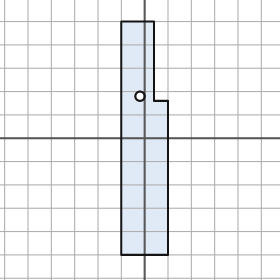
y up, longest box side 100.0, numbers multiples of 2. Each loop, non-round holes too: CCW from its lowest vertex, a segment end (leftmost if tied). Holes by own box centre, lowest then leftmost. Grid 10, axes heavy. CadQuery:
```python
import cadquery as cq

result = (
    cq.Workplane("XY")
    .moveTo(-10.0, -50.0)
    .lineTo(10.0, -50.0)
    .lineTo(10.0, 16.0)
    .lineTo(4.0, 16.0)
    .lineTo(4.0, 50.0)
    .lineTo(-10.0, 50.0)
    .close()
    .moveTo(-2.0, 18.0)
    .circle(2.0)
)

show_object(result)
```